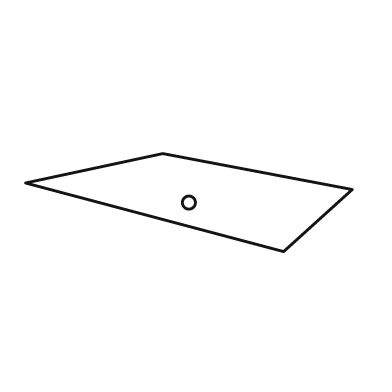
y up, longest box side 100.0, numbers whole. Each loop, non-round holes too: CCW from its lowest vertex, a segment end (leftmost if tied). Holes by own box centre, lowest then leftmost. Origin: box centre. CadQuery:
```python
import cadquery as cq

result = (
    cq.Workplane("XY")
    .moveTo(29.0, -15.0)
    .lineTo(50.0, 4.0)
    .lineTo(-8.0, 15.0)
    .lineTo(-50.0, 6.0)
    .close()
    .moveTo(0.0, 0.0)
    .circle(2.0)
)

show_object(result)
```